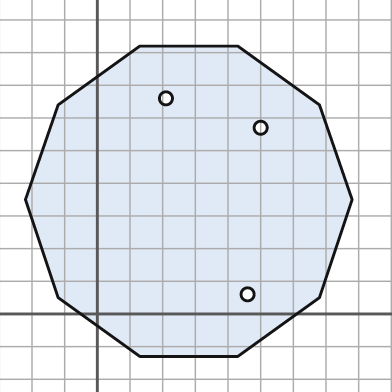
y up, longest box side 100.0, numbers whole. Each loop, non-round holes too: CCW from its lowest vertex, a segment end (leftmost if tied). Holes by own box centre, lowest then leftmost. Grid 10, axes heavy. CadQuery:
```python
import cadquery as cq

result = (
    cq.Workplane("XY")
    .moveTo(13.0, -13.0)
    .lineTo(43.0, -13.0)
    .lineTo(68.0, 5.0)
    .lineTo(78.0, 35.0)
    .lineTo(68.0, 64.0)
    .lineTo(43.0, 82.0)
    .lineTo(13.0, 82.0)
    .lineTo(-12.0, 64.0)
    .lineTo(-22.0, 35.0)
    .lineTo(-12.0, 5.0)
    .close()
    .moveTo(46.0, 6.0)
    .circle(2.0)
    .moveTo(50.0, 57.0)
    .circle(2.0)
    .moveTo(21.0, 66.0)
    .circle(2.0)
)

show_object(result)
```